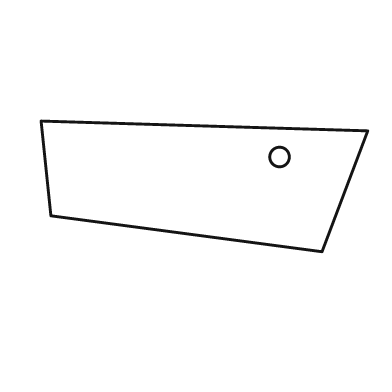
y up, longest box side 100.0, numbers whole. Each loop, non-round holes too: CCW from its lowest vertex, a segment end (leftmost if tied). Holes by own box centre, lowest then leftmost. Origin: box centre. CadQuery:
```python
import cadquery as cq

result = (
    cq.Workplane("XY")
    .moveTo(36.0, -20.0)
    .lineTo(50.0, 17.0)
    .lineTo(-50.0, 20.0)
    .lineTo(-47.0, -9.0)
    .close()
    .moveTo(23.0, 9.0)
    .circle(3.0)
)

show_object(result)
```